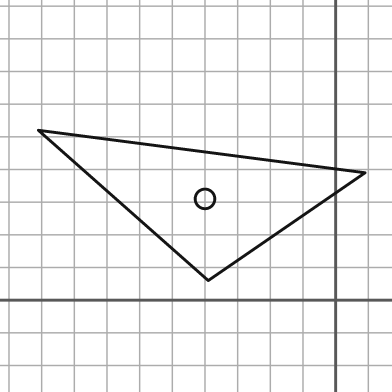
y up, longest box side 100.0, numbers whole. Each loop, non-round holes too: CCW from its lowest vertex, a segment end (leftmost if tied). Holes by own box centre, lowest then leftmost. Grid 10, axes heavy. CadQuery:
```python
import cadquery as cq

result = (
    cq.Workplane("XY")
    .moveTo(-39.0, 6.0)
    .lineTo(9.0, 39.0)
    .lineTo(-91.0, 52.0)
    .close()
    .moveTo(-40.0, 31.0)
    .circle(3.0)
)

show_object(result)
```